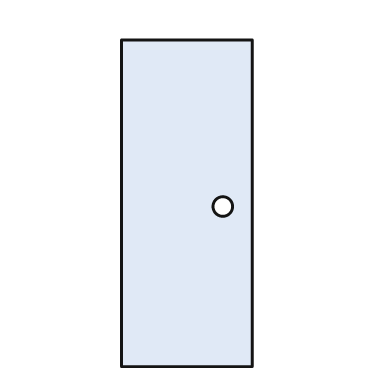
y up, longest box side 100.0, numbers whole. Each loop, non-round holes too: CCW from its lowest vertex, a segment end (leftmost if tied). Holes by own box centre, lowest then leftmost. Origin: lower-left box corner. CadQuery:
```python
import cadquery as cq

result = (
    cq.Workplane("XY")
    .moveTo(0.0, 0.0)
    .lineTo(40.0, 0.0)
    .lineTo(40.0, 100.0)
    .lineTo(0.0, 100.0)
    .close()
    .moveTo(31.0, 49.0)
    .circle(3.0)
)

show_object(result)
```